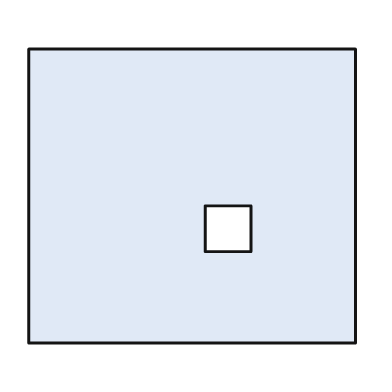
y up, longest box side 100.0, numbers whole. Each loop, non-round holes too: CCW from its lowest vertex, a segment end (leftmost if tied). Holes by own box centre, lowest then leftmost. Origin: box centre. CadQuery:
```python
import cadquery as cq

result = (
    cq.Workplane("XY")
    .moveTo(-50.0, -45.0)
    .lineTo(50.0, -45.0)
    .lineTo(50.0, 45.0)
    .lineTo(-50.0, 45.0)
    .close()
    .moveTo(4.0, -17.0)
    .lineTo(18.0, -17.0)
    .lineTo(18.0, -3.0)
    .lineTo(4.0, -3.0)
    .close()
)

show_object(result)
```